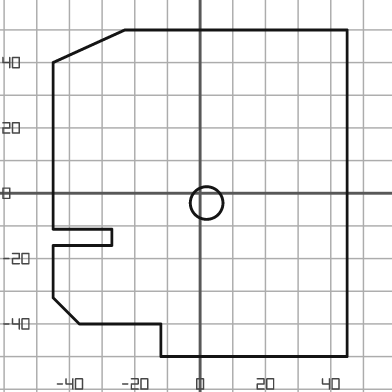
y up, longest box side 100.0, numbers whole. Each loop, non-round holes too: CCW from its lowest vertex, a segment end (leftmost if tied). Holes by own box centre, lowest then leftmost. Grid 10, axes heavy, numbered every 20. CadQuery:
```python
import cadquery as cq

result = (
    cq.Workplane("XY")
    .moveTo(-12.0, -50.0)
    .lineTo(45.0, -50.0)
    .lineTo(45.0, 50.0)
    .lineTo(-23.0, 50.0)
    .lineTo(-45.0, 40.0)
    .lineTo(-45.0, -11.0)
    .lineTo(-27.0, -11.0)
    .lineTo(-27.0, -16.0)
    .lineTo(-45.0, -16.0)
    .lineTo(-45.0, -32.0)
    .lineTo(-37.0, -40.0)
    .lineTo(-12.0, -40.0)
    .close()
    .moveTo(2.0, -3.0)
    .circle(5.0)
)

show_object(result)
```